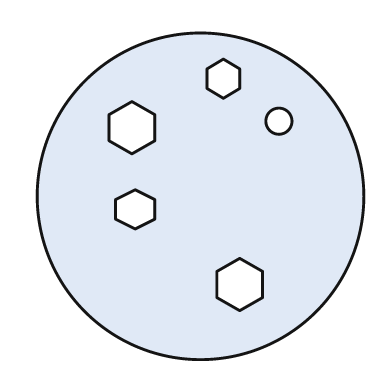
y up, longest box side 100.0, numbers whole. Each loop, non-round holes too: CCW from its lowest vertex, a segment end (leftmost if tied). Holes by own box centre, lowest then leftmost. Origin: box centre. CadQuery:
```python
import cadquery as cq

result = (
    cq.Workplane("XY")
    .moveTo(0.0, 0.0)
    .circle(50.0)
    .moveTo(12.0, -35.0)
    .lineTo(19.0, -31.0)
    .lineTo(19.0, -23.0)
    .lineTo(12.0, -19.0)
    .lineTo(5.0, -23.0)
    .lineTo(5.0, -31.0)
    .close()
    .moveTo(-20.0, -10.0)
    .lineTo(-14.0, -7.0)
    .lineTo(-14.0, -1.0)
    .lineTo(-20.0, 2.0)
    .lineTo(-26.0, -1.0)
    .lineTo(-26.0, -7.0)
    .close()
    .moveTo(-21.0, 13.0)
    .lineTo(-14.0, 17.0)
    .lineTo(-14.0, 25.0)
    .lineTo(-21.0, 29.0)
    .lineTo(-28.0, 25.0)
    .lineTo(-28.0, 17.0)
    .close()
    .moveTo(24.0, 23.0)
    .circle(4.0)
    .moveTo(7.0, 30.0)
    .lineTo(12.0, 33.0)
    .lineTo(12.0, 39.0)
    .lineTo(7.0, 42.0)
    .lineTo(2.0, 39.0)
    .lineTo(2.0, 33.0)
    .close()
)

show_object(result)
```